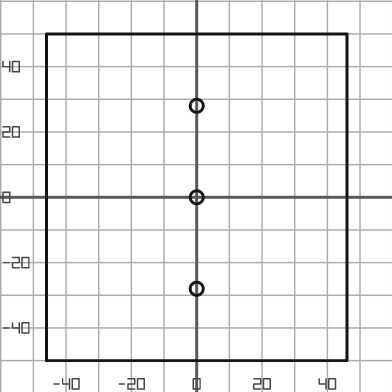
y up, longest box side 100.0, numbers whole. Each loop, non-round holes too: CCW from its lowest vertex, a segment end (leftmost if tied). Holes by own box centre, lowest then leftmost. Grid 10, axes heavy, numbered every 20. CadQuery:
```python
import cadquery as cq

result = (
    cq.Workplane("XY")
    .moveTo(-46.0, -50.0)
    .lineTo(46.0, -50.0)
    .lineTo(46.0, 50.0)
    .lineTo(-46.0, 50.0)
    .close()
    .moveTo(0.0, -28.0)
    .circle(2.0)
    .moveTo(0.0, 0.0)
    .circle(2.0)
    .moveTo(0.0, 28.0)
    .circle(2.0)
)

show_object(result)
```